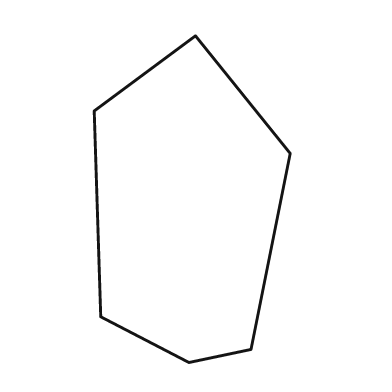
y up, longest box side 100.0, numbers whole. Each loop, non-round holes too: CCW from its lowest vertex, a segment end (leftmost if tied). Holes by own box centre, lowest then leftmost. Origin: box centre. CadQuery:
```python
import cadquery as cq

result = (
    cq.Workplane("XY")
    .moveTo(-1.0, -50.0)
    .lineTo(18.0, -46.0)
    .lineTo(30.0, 14.0)
    .lineTo(1.0, 50.0)
    .lineTo(-30.0, 27.0)
    .lineTo(-28.0, -36.0)
    .close()
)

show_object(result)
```